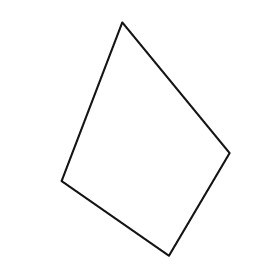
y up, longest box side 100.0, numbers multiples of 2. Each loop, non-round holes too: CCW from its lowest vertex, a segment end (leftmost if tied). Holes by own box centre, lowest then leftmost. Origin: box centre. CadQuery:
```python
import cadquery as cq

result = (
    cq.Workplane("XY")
    .moveTo(10.0, -50.0)
    .lineTo(36.0, -6.0)
    .lineTo(-10.0, 50.0)
    .lineTo(-36.0, -18.0)
    .close()
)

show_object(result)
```